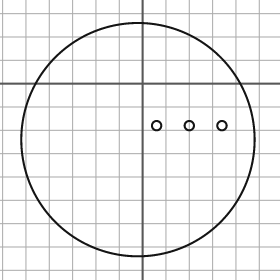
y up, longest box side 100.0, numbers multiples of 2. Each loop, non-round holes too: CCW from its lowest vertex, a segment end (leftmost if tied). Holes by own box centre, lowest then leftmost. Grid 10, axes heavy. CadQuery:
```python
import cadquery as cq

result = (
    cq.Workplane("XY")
    .moveTo(-2.0, -24.0)
    .circle(50.0)
    .moveTo(6.0, -18.0)
    .circle(2.0)
    .moveTo(20.0, -18.0)
    .circle(2.0)
    .moveTo(34.0, -18.0)
    .circle(2.0)
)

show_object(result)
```